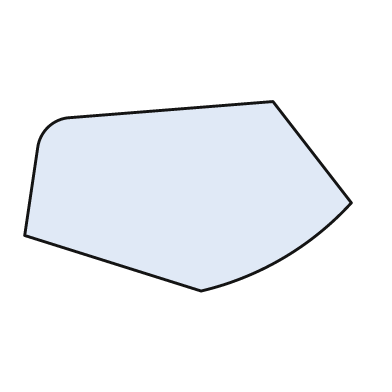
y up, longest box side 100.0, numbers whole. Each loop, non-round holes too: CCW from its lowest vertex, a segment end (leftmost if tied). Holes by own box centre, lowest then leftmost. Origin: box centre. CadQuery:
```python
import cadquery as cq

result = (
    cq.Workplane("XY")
    .moveTo(4.0, -29.0)
    .threePointArc((29.0, -19.0), (50.0, -2.0))
    .lineTo(26.0, 29.0)
    .lineTo(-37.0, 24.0)
    .threePointArc((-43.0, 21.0), (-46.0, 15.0))
    .lineTo(-50.0, -12.0)
    .close()
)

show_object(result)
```